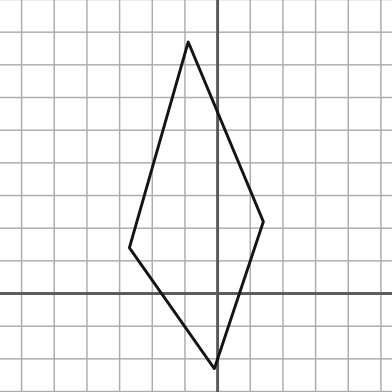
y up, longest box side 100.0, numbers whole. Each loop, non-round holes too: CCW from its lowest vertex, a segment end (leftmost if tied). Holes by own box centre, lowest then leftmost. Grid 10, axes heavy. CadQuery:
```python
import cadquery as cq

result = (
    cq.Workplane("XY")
    .moveTo(-1.0, -23.0)
    .lineTo(14.0, 22.0)
    .lineTo(-9.0, 77.0)
    .lineTo(-27.0, 14.0)
    .close()
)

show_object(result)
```